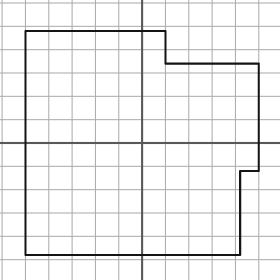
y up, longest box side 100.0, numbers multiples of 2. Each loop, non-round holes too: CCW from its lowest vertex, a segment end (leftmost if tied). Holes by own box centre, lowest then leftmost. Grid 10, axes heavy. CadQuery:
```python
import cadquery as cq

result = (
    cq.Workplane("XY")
    .moveTo(-50.0, -48.0)
    .lineTo(42.0, -48.0)
    .lineTo(42.0, -12.0)
    .lineTo(50.0, -12.0)
    .lineTo(50.0, 34.0)
    .lineTo(10.0, 34.0)
    .lineTo(10.0, 48.0)
    .lineTo(-50.0, 48.0)
    .close()
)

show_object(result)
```